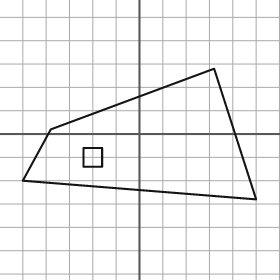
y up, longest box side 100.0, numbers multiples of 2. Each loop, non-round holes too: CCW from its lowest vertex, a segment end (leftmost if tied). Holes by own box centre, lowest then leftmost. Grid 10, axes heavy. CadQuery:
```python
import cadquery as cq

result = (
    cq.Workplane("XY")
    .moveTo(50.0, -28.0)
    .lineTo(32.0, 28.0)
    .lineTo(-38.0, 2.0)
    .lineTo(-50.0, -20.0)
    .close()
    .moveTo(-24.0, -14.0)
    .lineTo(-16.0, -14.0)
    .lineTo(-16.0, -6.0)
    .lineTo(-24.0, -6.0)
    .close()
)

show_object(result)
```